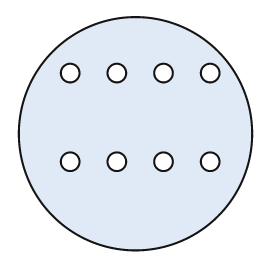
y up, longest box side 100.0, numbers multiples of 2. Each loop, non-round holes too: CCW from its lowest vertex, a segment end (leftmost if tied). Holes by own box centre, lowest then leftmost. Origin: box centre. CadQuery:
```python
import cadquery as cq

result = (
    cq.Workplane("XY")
    .moveTo(0.0, 0.0)
    .circle(50.0)
    .moveTo(-28.0, -12.0)
    .circle(4.0)
    .moveTo(-8.0, -12.0)
    .circle(4.0)
    .moveTo(12.0, -12.0)
    .circle(4.0)
    .moveTo(32.0, -12.0)
    .circle(4.0)
    .moveTo(-28.0, 26.0)
    .circle(4.0)
    .moveTo(-8.0, 26.0)
    .circle(4.0)
    .moveTo(12.0, 26.0)
    .circle(4.0)
    .moveTo(32.0, 26.0)
    .circle(4.0)
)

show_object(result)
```